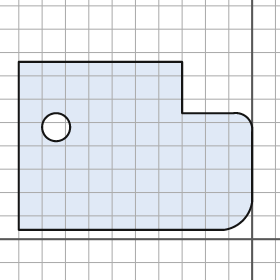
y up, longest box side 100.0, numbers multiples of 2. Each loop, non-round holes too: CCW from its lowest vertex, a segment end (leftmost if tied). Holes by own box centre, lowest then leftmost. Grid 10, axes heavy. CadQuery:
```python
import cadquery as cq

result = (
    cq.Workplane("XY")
    .moveTo(-100.0, 4.0)
    .lineTo(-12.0, 4.0)
    .threePointArc((-4.0, 8.0), (0.0, 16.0))
    .lineTo(0.0, 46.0)
    .threePointArc((-2.0, 52.0), (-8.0, 54.0))
    .lineTo(-30.0, 54.0)
    .lineTo(-30.0, 76.0)
    .lineTo(-100.0, 76.0)
    .close()
    .moveTo(-84.0, 48.0)
    .circle(6.0)
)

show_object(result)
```